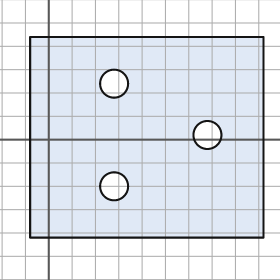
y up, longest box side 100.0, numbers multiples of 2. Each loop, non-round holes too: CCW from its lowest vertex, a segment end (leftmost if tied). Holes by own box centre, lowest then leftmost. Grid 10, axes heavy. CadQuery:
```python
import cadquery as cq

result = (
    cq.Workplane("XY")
    .moveTo(-8.0, -42.0)
    .lineTo(92.0, -42.0)
    .lineTo(92.0, 44.0)
    .lineTo(-8.0, 44.0)
    .close()
    .moveTo(28.0, -20.0)
    .circle(6.0)
    .moveTo(68.0, 2.0)
    .circle(6.0)
    .moveTo(28.0, 24.0)
    .circle(6.0)
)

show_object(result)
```